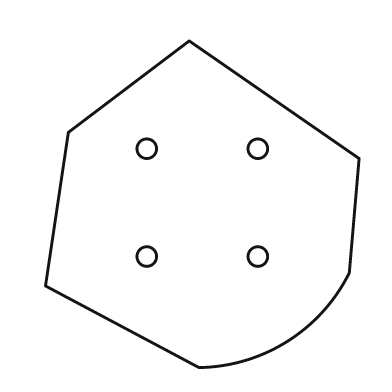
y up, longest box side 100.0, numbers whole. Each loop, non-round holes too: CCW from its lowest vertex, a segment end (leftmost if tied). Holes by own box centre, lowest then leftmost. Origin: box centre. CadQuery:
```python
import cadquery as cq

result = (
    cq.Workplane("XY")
    .moveTo(-1.0, -50.0)
    .threePointArc((26.0, -42.0), (45.0, -21.0))
    .lineTo(48.0, 14.0)
    .lineTo(-4.0, 50.0)
    .lineTo(-41.0, 22.0)
    .lineTo(-48.0, -25.0)
    .close()
    .moveTo(-17.0, -16.0)
    .circle(3.0)
    .moveTo(17.0, -16.0)
    .circle(3.0)
    .moveTo(-17.0, 17.0)
    .circle(3.0)
    .moveTo(17.0, 17.0)
    .circle(3.0)
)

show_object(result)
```